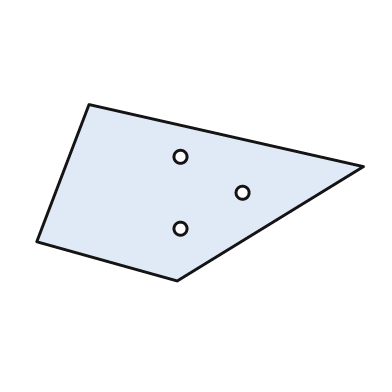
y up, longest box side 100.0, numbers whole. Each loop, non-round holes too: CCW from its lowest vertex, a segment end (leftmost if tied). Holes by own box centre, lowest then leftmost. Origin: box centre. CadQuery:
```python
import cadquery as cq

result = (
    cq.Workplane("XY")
    .moveTo(-7.0, -27.0)
    .lineTo(50.0, 8.0)
    .lineTo(-34.0, 27.0)
    .lineTo(-50.0, -15.0)
    .close()
    .moveTo(-6.0, -11.0)
    .circle(2.0)
    .moveTo(13.0, 0.0)
    .circle(2.0)
    .moveTo(-6.0, 11.0)
    .circle(2.0)
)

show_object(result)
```